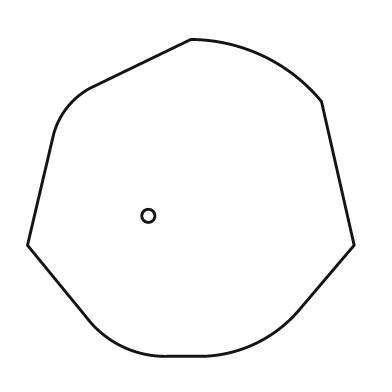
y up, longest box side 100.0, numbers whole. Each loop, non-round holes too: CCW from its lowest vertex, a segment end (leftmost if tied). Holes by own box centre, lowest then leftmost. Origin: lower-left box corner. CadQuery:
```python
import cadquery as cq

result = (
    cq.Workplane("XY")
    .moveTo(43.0, 0.0)
    .lineTo(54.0, 0.0)
    .threePointArc((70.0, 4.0), (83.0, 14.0))
    .lineTo(100.0, 34.0)
    .lineTo(90.0, 78.0)
    .threePointArc((72.0, 92.0), (50.0, 97.0))
    .lineTo(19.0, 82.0)
    .threePointArc((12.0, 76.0), (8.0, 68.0))
    .lineTo(0.0, 34.0)
    .lineTo(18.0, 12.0)
    .threePointArc((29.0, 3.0), (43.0, 0.0))
    .close()
    .moveTo(37.0, 43.0)
    .circle(2.0)
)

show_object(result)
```